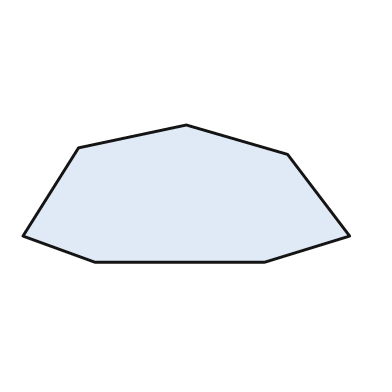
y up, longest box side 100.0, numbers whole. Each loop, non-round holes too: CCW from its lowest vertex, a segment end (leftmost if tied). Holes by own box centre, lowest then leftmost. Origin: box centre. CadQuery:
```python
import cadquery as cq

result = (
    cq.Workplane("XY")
    .moveTo(-28.0, -21.0)
    .lineTo(24.0, -21.0)
    .lineTo(50.0, -13.0)
    .lineTo(31.0, 12.0)
    .lineTo(0.0, 21.0)
    .lineTo(-33.0, 14.0)
    .lineTo(-50.0, -13.0)
    .close()
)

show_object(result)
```